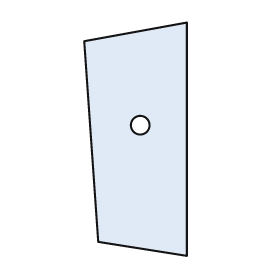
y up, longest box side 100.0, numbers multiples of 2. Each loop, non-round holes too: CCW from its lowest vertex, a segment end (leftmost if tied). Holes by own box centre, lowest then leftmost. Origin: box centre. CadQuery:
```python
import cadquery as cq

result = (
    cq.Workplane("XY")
    .moveTo(22.0, -50.0)
    .lineTo(22.0, 50.0)
    .lineTo(-22.0, 42.0)
    .lineTo(-16.0, -44.0)
    .close()
    .moveTo(2.0, 6.0)
    .circle(4.0)
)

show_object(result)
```